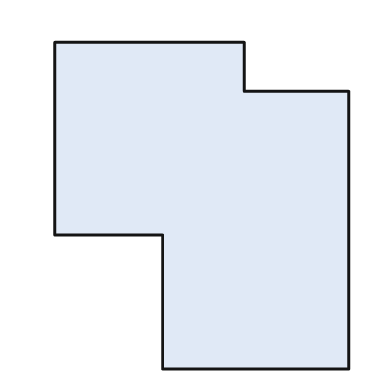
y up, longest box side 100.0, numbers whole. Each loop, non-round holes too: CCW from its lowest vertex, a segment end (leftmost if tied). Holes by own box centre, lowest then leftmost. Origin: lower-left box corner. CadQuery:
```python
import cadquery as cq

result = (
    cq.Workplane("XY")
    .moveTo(33.0, 0.0)
    .lineTo(90.0, 0.0)
    .lineTo(90.0, 85.0)
    .lineTo(58.0, 85.0)
    .lineTo(58.0, 100.0)
    .lineTo(0.0, 100.0)
    .lineTo(0.0, 41.0)
    .lineTo(33.0, 41.0)
    .close()
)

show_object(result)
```